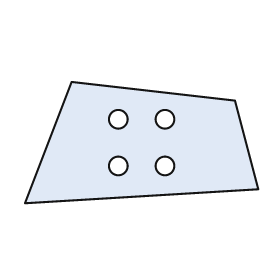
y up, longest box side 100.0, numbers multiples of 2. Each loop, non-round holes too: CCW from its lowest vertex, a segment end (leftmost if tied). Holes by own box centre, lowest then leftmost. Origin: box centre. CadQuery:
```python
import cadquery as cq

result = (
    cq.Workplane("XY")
    .moveTo(-50.0, -26.0)
    .lineTo(50.0, -20.0)
    .lineTo(40.0, 18.0)
    .lineTo(-30.0, 26.0)
    .close()
    .moveTo(-10.0, -10.0)
    .circle(4.0)
    .moveTo(10.0, -10.0)
    .circle(4.0)
    .moveTo(-10.0, 10.0)
    .circle(4.0)
    .moveTo(10.0, 10.0)
    .circle(4.0)
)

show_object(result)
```